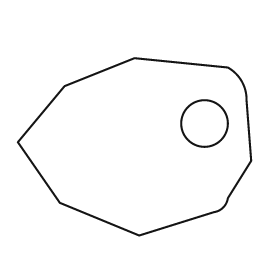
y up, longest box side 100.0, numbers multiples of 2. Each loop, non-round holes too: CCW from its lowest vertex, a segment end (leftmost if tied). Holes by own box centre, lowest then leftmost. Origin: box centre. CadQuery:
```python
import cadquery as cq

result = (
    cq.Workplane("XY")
    .moveTo(2.0, -38.0)
    .lineTo(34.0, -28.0)
    .threePointArc((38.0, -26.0), (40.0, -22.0))
    .lineTo(50.0, -6.0)
    .lineTo(48.0, 20.0)
    .threePointArc((46.0, 28.0), (40.0, 34.0))
    .lineTo(0.0, 38.0)
    .lineTo(-30.0, 26.0)
    .lineTo(-50.0, 2.0)
    .lineTo(-32.0, -24.0)
    .close()
    .moveTo(30.0, 10.0)
    .circle(10.0)
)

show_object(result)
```